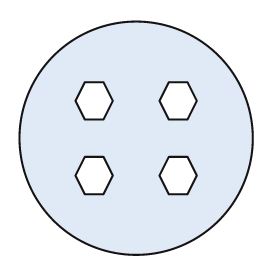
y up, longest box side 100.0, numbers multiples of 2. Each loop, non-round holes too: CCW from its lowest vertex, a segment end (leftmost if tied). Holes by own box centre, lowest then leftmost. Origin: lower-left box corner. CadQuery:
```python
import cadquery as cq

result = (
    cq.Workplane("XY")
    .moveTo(50.0, 50.0)
    .circle(50.0)
    .moveTo(28.0, 26.0)
    .lineTo(36.0, 26.0)
    .lineTo(40.0, 34.0)
    .lineTo(36.0, 42.0)
    .lineTo(28.0, 42.0)
    .lineTo(24.0, 34.0)
    .close()
    .moveTo(64.0, 26.0)
    .lineTo(72.0, 26.0)
    .lineTo(76.0, 34.0)
    .lineTo(72.0, 42.0)
    .lineTo(64.0, 42.0)
    .lineTo(60.0, 34.0)
    .close()
    .moveTo(28.0, 58.0)
    .lineTo(36.0, 58.0)
    .lineTo(40.0, 66.0)
    .lineTo(36.0, 74.0)
    .lineTo(28.0, 74.0)
    .lineTo(24.0, 66.0)
    .close()
    .moveTo(64.0, 58.0)
    .lineTo(72.0, 58.0)
    .lineTo(76.0, 66.0)
    .lineTo(72.0, 74.0)
    .lineTo(64.0, 74.0)
    .lineTo(60.0, 66.0)
    .close()
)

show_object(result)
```